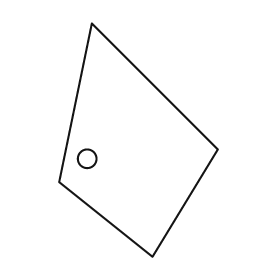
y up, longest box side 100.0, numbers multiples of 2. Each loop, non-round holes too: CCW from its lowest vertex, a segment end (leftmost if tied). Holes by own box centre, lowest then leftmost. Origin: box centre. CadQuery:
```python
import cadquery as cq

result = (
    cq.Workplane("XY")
    .moveTo(6.0, -50.0)
    .lineTo(34.0, -4.0)
    .lineTo(-20.0, 50.0)
    .lineTo(-34.0, -18.0)
    .close()
    .moveTo(-22.0, -8.0)
    .circle(4.0)
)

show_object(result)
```